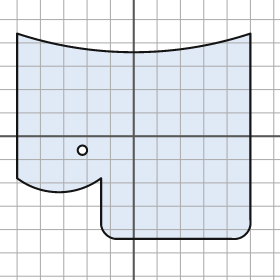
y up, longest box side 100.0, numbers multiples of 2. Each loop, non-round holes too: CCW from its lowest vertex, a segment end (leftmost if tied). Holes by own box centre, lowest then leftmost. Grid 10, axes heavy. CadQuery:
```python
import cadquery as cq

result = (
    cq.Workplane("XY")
    .moveTo(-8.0, -44.0)
    .lineTo(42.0, -44.0)
    .threePointArc((48.0, -42.0), (50.0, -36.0))
    .lineTo(50.0, 44.0)
    .threePointArc((0.0, 36.0), (-50.0, 44.0))
    .lineTo(-50.0, -18.0)
    .threePointArc((-32.0, -24.0), (-14.0, -18.0))
    .lineTo(-14.0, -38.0)
    .threePointArc((-12.0, -42.0), (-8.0, -44.0))
    .close()
    .moveTo(-22.0, -6.0)
    .circle(2.0)
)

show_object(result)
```